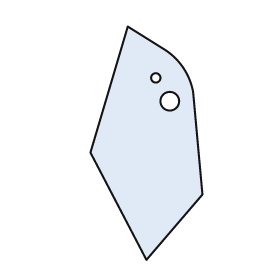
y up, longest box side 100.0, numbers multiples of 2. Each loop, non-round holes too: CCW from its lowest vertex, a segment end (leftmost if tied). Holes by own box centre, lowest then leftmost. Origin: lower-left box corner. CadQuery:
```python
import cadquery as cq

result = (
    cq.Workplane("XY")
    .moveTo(24.0, 0.0)
    .lineTo(48.0, 28.0)
    .lineTo(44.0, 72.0)
    .threePointArc((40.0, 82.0), (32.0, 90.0))
    .lineTo(16.0, 100.0)
    .lineTo(0.0, 46.0)
    .close()
    .moveTo(34.0, 68.0)
    .circle(4.0)
    .moveTo(28.0, 78.0)
    .circle(2.0)
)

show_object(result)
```